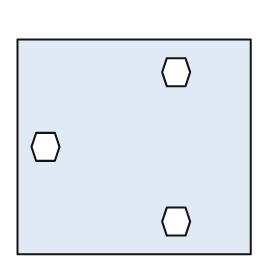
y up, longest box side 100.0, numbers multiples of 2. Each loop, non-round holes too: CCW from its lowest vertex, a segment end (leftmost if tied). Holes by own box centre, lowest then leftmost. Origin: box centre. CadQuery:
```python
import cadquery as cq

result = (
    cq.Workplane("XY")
    .moveTo(-50.0, -46.0)
    .lineTo(50.0, -46.0)
    .lineTo(50.0, 46.0)
    .lineTo(-50.0, 46.0)
    .close()
    .moveTo(14.0, -38.0)
    .lineTo(22.0, -38.0)
    .lineTo(24.0, -32.0)
    .lineTo(22.0, -26.0)
    .lineTo(14.0, -26.0)
    .lineTo(12.0, -32.0)
    .close()
    .moveTo(-42.0, -6.0)
    .lineTo(-34.0, -6.0)
    .lineTo(-32.0, 0.0)
    .lineTo(-34.0, 6.0)
    .lineTo(-42.0, 6.0)
    .lineTo(-44.0, 0.0)
    .close()
    .moveTo(14.0, 26.0)
    .lineTo(22.0, 26.0)
    .lineTo(24.0, 32.0)
    .lineTo(22.0, 38.0)
    .lineTo(14.0, 38.0)
    .lineTo(12.0, 32.0)
    .close()
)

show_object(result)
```